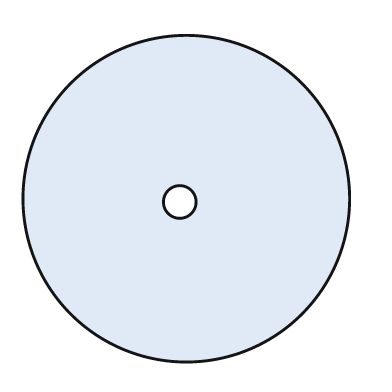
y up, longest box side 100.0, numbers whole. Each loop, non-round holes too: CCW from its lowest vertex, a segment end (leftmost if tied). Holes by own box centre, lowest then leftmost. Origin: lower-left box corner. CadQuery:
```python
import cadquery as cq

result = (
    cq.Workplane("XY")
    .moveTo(50.0, 50.0)
    .circle(50.0)
    .moveTo(48.0, 49.0)
    .circle(5.0)
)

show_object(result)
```